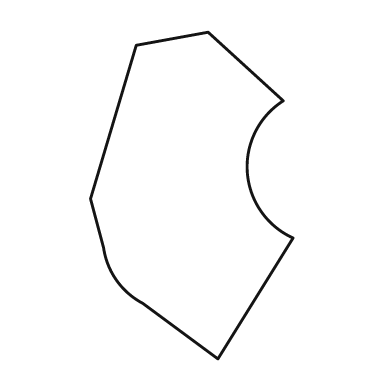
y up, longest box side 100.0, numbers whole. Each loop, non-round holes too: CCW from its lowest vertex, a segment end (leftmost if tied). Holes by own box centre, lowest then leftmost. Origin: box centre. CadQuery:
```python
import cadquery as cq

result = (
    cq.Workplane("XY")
    .moveTo(8.0, -50.0)
    .lineTo(31.0, -13.0)
    .threePointArc((17.0, 7.0), (28.0, 29.0))
    .lineTo(5.0, 50.0)
    .lineTo(-17.0, 46.0)
    .lineTo(-31.0, -1.0)
    .lineTo(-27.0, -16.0)
    .threePointArc((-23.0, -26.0), (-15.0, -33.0))
    .close()
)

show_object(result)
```